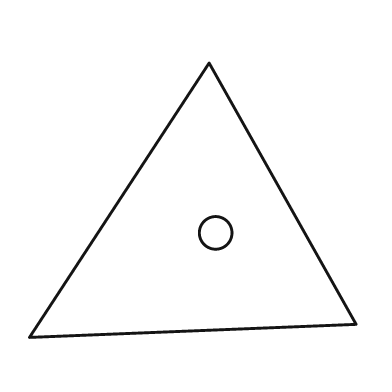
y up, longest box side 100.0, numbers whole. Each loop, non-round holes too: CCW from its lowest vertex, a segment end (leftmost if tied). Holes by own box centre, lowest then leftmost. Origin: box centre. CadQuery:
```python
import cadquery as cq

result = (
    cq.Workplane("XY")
    .moveTo(-50.0, -42.0)
    .lineTo(50.0, -38.0)
    .lineTo(5.0, 42.0)
    .close()
    .moveTo(7.0, -10.0)
    .circle(5.0)
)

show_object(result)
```